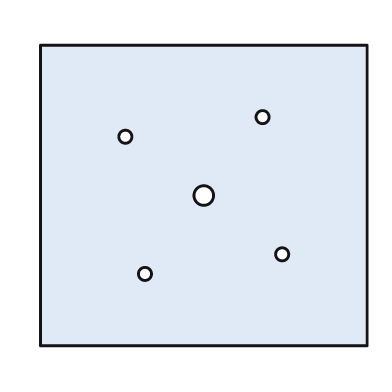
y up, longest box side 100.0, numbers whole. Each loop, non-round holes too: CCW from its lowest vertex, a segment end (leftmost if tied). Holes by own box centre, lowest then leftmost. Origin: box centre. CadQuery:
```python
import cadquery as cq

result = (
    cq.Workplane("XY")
    .moveTo(-50.0, -46.0)
    .lineTo(50.0, -46.0)
    .lineTo(50.0, 46.0)
    .lineTo(-50.0, 46.0)
    .close()
    .moveTo(-18.0, -24.0)
    .circle(2.0)
    .moveTo(24.0, -18.0)
    .circle(2.0)
    .moveTo(0.0, 0.0)
    .circle(3.0)
    .moveTo(-24.0, 18.0)
    .circle(2.0)
    .moveTo(18.0, 24.0)
    .circle(2.0)
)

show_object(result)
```